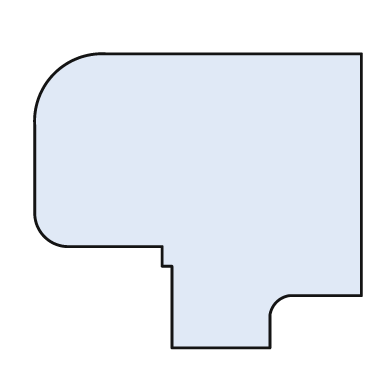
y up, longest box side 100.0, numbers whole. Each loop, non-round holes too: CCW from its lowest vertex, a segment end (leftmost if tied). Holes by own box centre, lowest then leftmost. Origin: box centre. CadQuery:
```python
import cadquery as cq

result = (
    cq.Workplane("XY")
    .moveTo(-8.0, -45.0)
    .lineTo(22.0, -45.0)
    .lineTo(22.0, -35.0)
    .threePointArc((24.0, -31.0), (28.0, -29.0))
    .lineTo(50.0, -29.0)
    .lineTo(50.0, 45.0)
    .lineTo(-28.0, 45.0)
    .threePointArc((-44.0, 39.0), (-50.0, 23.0))
    .lineTo(-50.0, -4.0)
    .threePointArc((-47.0, -11.0), (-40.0, -14.0))
    .lineTo(-11.0, -14.0)
    .lineTo(-11.0, -20.0)
    .lineTo(-8.0, -20.0)
    .close()
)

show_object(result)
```